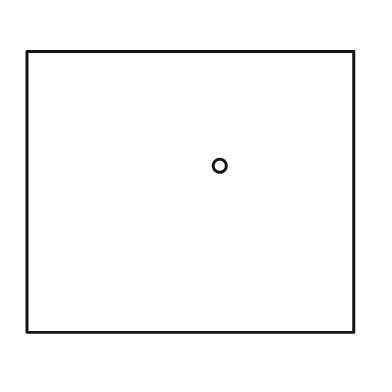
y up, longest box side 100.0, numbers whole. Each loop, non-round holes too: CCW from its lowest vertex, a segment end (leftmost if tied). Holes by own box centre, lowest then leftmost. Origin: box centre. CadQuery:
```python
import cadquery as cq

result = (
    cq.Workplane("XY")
    .moveTo(-50.0, -43.0)
    .lineTo(50.0, -43.0)
    .lineTo(50.0, 43.0)
    .lineTo(-50.0, 43.0)
    .close()
    .moveTo(9.0, 8.0)
    .circle(2.0)
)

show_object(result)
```